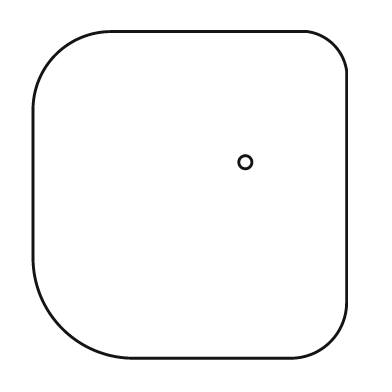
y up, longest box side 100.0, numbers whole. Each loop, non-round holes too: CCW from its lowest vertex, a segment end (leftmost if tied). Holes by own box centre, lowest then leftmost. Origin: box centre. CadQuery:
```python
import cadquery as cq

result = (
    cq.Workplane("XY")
    .moveTo(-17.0, -50.0)
    .lineTo(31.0, -50.0)
    .threePointArc((43.0, -45.0), (48.0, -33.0))
    .lineTo(48.0, 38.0)
    .threePointArc((44.0, 46.0), (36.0, 50.0))
    .lineTo(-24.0, 50.0)
    .threePointArc((-41.0, 43.0), (-48.0, 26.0))
    .lineTo(-48.0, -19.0)
    .threePointArc((-39.0, -41.0), (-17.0, -50.0))
    .close()
    .moveTo(17.0, 10.0)
    .circle(2.0)
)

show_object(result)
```